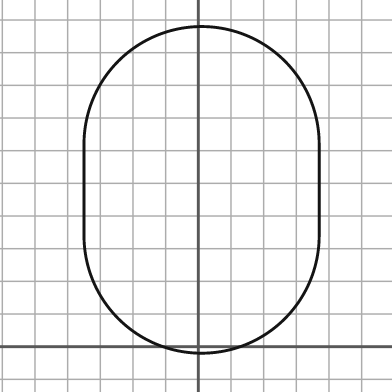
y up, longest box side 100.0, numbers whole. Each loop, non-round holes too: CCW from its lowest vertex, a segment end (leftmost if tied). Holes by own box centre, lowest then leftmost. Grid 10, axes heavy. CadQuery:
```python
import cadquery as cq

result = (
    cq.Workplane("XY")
    .moveTo(-35.0, 34.0)
    .threePointArc((1.0, -2.0), (37.0, 34.0))
    .lineTo(37.0, 62.0)
    .threePointArc((1.0, 98.0), (-35.0, 62.0))
    .close()
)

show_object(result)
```